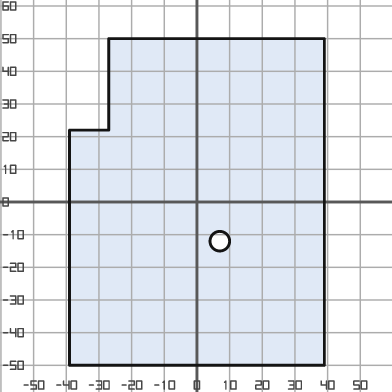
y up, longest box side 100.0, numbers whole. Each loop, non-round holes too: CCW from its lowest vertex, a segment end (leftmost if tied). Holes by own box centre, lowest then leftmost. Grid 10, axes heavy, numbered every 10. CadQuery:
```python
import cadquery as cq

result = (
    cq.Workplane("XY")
    .moveTo(-39.0, -50.0)
    .lineTo(39.0, -50.0)
    .lineTo(39.0, 50.0)
    .lineTo(-27.0, 50.0)
    .lineTo(-27.0, 22.0)
    .lineTo(-39.0, 22.0)
    .close()
    .moveTo(7.0, -12.0)
    .circle(3.0)
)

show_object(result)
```